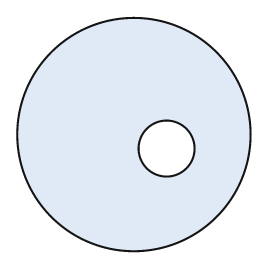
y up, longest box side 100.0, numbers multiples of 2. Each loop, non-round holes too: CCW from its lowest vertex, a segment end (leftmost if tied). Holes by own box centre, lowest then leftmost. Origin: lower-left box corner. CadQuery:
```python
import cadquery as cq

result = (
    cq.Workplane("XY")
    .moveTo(50.0, 50.0)
    .circle(50.0)
    .moveTo(64.0, 44.0)
    .circle(12.0)
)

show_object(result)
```